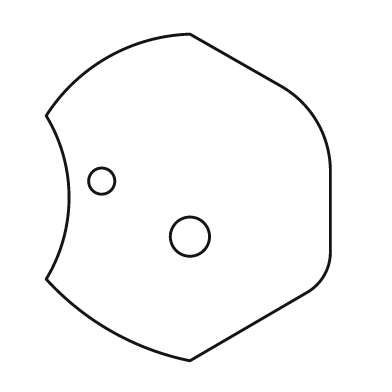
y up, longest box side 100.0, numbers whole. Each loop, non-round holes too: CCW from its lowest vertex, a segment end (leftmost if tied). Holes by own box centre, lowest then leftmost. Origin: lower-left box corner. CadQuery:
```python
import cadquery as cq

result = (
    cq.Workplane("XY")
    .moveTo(44.0, 0.0)
    .lineTo(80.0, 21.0)
    .threePointArc((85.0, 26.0), (87.0, 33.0))
    .lineTo(87.0, 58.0)
    .threePointArc((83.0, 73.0), (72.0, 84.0))
    .lineTo(44.0, 100.0)
    .threePointArc((19.0, 93.0), (0.0, 75.0))
    .threePointArc((7.0, 50.0), (0.0, 25.0))
    .threePointArc((20.0, 9.0), (44.0, 0.0))
    .close()
    .moveTo(44.0, 38.0)
    .circle(6.0)
    .moveTo(17.0, 55.0)
    .circle(4.0)
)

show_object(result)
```